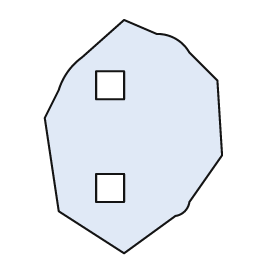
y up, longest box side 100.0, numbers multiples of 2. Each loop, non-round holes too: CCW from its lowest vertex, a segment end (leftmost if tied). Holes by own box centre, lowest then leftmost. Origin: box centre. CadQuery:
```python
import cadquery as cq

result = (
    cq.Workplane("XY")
    .moveTo(-4.0, -50.0)
    .lineTo(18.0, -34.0)
    .threePointArc((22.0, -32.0), (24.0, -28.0))
    .lineTo(38.0, -8.0)
    .lineTo(36.0, 24.0)
    .lineTo(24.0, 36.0)
    .threePointArc((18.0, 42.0), (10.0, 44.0))
    .lineTo(-4.0, 50.0)
    .lineTo(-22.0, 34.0)
    .threePointArc((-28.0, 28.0), (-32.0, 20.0))
    .lineTo(-38.0, 8.0)
    .lineTo(-32.0, -32.0)
    .close()
    .moveTo(-16.0, -28.0)
    .lineTo(-4.0, -28.0)
    .lineTo(-4.0, -16.0)
    .lineTo(-16.0, -16.0)
    .close()
    .moveTo(-16.0, 16.0)
    .lineTo(-4.0, 16.0)
    .lineTo(-4.0, 28.0)
    .lineTo(-16.0, 28.0)
    .close()
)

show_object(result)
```